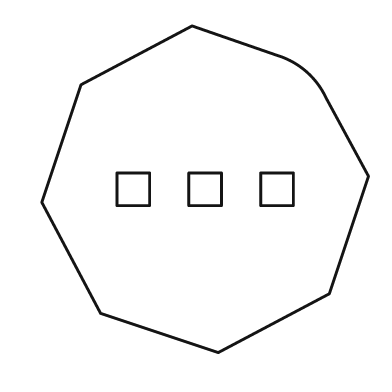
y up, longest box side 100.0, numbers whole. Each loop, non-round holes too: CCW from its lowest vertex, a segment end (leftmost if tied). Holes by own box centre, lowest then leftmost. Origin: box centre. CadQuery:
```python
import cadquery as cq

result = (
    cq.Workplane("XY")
    .moveTo(4.0, -50.0)
    .lineTo(38.0, -32.0)
    .lineTo(50.0, 4.0)
    .lineTo(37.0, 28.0)
    .threePointArc((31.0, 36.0), (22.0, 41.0))
    .lineTo(-4.0, 50.0)
    .lineTo(-38.0, 32.0)
    .lineTo(-50.0, -4.0)
    .lineTo(-32.0, -38.0)
    .close()
    .moveTo(-27.0, -5.0)
    .lineTo(-17.0, -5.0)
    .lineTo(-17.0, 5.0)
    .lineTo(-27.0, 5.0)
    .close()
    .moveTo(-5.0, -5.0)
    .lineTo(5.0, -5.0)
    .lineTo(5.0, 5.0)
    .lineTo(-5.0, 5.0)
    .close()
    .moveTo(17.0, -5.0)
    .lineTo(27.0, -5.0)
    .lineTo(27.0, 5.0)
    .lineTo(17.0, 5.0)
    .close()
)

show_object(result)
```